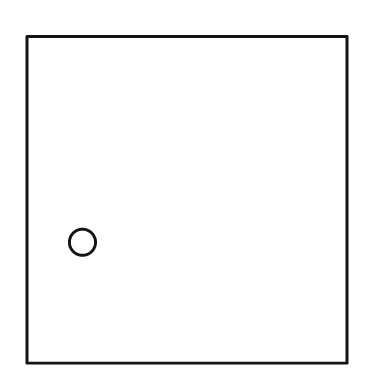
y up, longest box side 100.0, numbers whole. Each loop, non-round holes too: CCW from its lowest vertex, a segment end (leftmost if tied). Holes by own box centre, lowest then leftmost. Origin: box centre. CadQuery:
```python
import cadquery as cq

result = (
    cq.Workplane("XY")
    .moveTo(-49.0, -50.0)
    .lineTo(49.0, -50.0)
    .lineTo(49.0, 50.0)
    .lineTo(-49.0, 50.0)
    .close()
    .moveTo(-32.0, -13.0)
    .circle(4.0)
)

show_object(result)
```